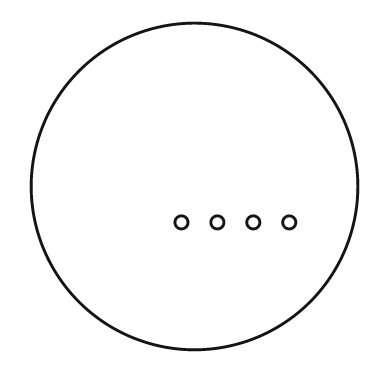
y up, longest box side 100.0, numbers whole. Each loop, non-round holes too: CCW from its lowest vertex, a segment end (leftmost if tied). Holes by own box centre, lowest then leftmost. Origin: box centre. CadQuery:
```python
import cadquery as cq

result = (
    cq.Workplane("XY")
    .moveTo(0.0, 0.0)
    .circle(50.0)
    .moveTo(-4.0, -11.0)
    .circle(2.0)
    .moveTo(7.0, -11.0)
    .circle(2.0)
    .moveTo(18.0, -11.0)
    .circle(2.0)
    .moveTo(29.0, -11.0)
    .circle(2.0)
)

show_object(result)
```